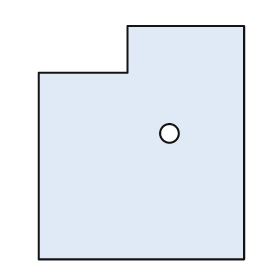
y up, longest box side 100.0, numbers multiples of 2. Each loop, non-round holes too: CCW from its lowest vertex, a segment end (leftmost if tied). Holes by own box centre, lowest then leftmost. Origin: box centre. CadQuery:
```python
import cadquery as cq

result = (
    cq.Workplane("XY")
    .moveTo(-44.0, -50.0)
    .lineTo(44.0, -50.0)
    .lineTo(44.0, 50.0)
    .lineTo(-6.0, 50.0)
    .lineTo(-6.0, 30.0)
    .lineTo(-44.0, 30.0)
    .close()
    .moveTo(12.0, 4.0)
    .circle(4.0)
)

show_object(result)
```